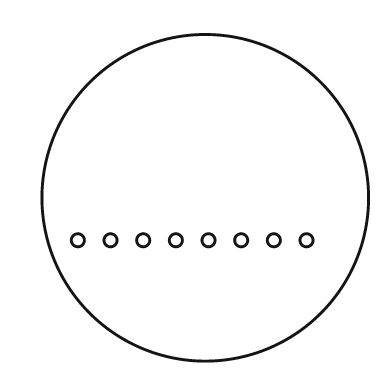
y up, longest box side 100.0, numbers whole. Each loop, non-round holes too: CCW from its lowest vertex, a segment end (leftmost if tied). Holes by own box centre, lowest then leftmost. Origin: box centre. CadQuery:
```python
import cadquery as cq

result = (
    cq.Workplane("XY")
    .moveTo(0.0, 0.0)
    .circle(50.0)
    .moveTo(-39.0, -13.0)
    .circle(2.0)
    .moveTo(-29.0, -13.0)
    .circle(2.0)
    .moveTo(-19.0, -13.0)
    .circle(2.0)
    .moveTo(-9.0, -13.0)
    .circle(2.0)
    .moveTo(1.0, -13.0)
    .circle(2.0)
    .moveTo(11.0, -13.0)
    .circle(2.0)
    .moveTo(21.0, -13.0)
    .circle(2.0)
    .moveTo(31.0, -13.0)
    .circle(2.0)
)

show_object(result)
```